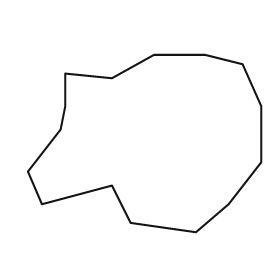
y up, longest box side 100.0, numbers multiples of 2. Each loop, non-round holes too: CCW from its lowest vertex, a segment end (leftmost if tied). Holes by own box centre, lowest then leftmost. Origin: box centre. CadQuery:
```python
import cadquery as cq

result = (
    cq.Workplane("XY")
    .moveTo(22.0, -38.0)
    .lineTo(36.0, -26.0)
    .lineTo(50.0, -8.0)
    .lineTo(50.0, 16.0)
    .lineTo(42.0, 34.0)
    .lineTo(26.0, 38.0)
    .lineTo(4.0, 38.0)
    .lineTo(-14.0, 28.0)
    .lineTo(-34.0, 30.0)
    .lineTo(-34.0, 16.0)
    .lineTo(-36.0, 6.0)
    .lineTo(-50.0, -12.0)
    .lineTo(-44.0, -26.0)
    .lineTo(-14.0, -18.0)
    .lineTo(-6.0, -34.0)
    .close()
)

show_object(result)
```